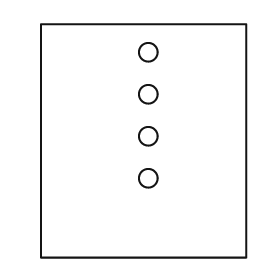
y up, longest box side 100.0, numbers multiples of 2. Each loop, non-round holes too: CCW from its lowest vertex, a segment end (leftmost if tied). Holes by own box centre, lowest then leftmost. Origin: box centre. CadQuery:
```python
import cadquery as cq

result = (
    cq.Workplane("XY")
    .moveTo(-44.0, -50.0)
    .lineTo(44.0, -50.0)
    .lineTo(44.0, 50.0)
    .lineTo(-44.0, 50.0)
    .close()
    .moveTo(2.0, -16.0)
    .circle(4.0)
    .moveTo(2.0, 2.0)
    .circle(4.0)
    .moveTo(2.0, 20.0)
    .circle(4.0)
    .moveTo(2.0, 38.0)
    .circle(4.0)
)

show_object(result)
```